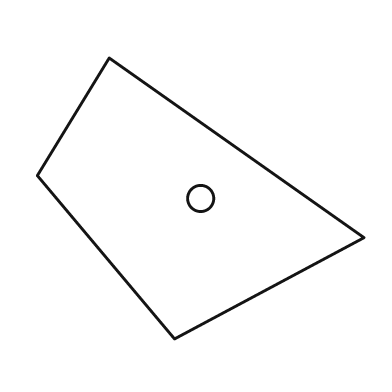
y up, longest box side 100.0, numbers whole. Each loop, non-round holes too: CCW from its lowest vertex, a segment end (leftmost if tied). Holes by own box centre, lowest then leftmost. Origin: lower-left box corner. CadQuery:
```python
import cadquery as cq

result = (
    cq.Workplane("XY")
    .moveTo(42.0, 0.0)
    .lineTo(100.0, 31.0)
    .lineTo(22.0, 86.0)
    .lineTo(0.0, 50.0)
    .close()
    .moveTo(50.0, 43.0)
    .circle(4.0)
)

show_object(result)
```